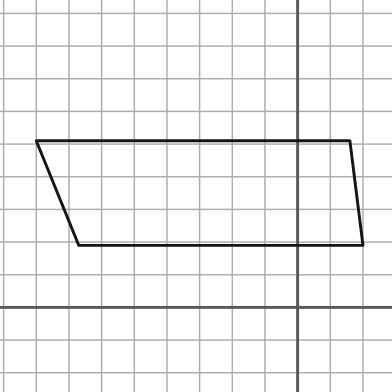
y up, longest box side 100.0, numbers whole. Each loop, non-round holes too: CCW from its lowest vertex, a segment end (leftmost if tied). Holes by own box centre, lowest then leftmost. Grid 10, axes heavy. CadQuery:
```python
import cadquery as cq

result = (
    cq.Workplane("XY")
    .moveTo(-67.0, 19.0)
    .lineTo(20.0, 19.0)
    .lineTo(16.0, 51.0)
    .lineTo(-80.0, 51.0)
    .close()
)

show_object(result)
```